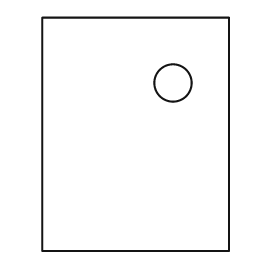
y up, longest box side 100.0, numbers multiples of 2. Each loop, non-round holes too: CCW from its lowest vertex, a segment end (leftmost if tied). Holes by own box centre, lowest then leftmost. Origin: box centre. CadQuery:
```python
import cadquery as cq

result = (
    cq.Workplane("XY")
    .moveTo(-40.0, -50.0)
    .lineTo(40.0, -50.0)
    .lineTo(40.0, 50.0)
    .lineTo(-40.0, 50.0)
    .close()
    .moveTo(16.0, 22.0)
    .circle(8.0)
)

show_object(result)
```